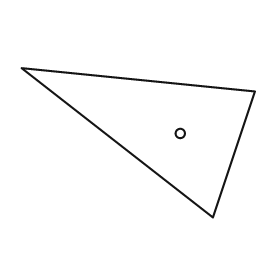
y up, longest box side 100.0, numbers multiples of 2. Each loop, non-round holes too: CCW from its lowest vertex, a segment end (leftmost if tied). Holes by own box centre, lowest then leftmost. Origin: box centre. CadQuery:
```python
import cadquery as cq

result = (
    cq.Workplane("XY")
    .moveTo(32.0, -32.0)
    .lineTo(50.0, 22.0)
    .lineTo(-50.0, 32.0)
    .close()
    .moveTo(18.0, 4.0)
    .circle(2.0)
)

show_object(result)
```